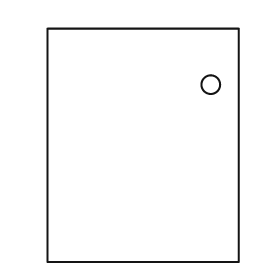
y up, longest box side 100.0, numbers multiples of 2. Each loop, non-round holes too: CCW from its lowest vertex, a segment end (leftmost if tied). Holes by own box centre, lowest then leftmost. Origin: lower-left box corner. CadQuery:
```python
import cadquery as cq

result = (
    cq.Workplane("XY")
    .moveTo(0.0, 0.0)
    .lineTo(82.0, 0.0)
    .lineTo(82.0, 100.0)
    .lineTo(0.0, 100.0)
    .close()
    .moveTo(70.0, 76.0)
    .circle(4.0)
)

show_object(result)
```